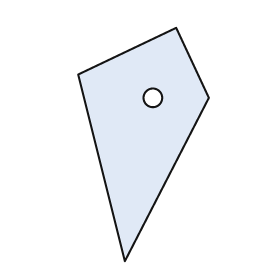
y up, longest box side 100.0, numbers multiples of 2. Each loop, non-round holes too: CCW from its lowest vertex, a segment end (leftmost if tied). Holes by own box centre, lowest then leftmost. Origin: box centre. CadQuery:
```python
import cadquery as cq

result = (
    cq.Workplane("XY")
    .moveTo(-8.0, -50.0)
    .lineTo(28.0, 20.0)
    .lineTo(14.0, 50.0)
    .lineTo(-28.0, 30.0)
    .close()
    .moveTo(4.0, 20.0)
    .circle(4.0)
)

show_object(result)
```